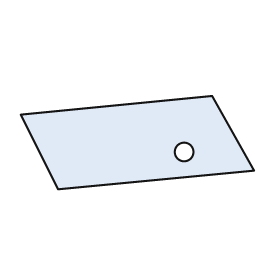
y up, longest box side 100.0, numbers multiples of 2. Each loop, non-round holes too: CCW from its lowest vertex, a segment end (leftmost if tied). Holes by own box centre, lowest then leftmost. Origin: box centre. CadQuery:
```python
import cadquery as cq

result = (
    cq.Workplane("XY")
    .moveTo(-34.0, -20.0)
    .lineTo(50.0, -12.0)
    .lineTo(32.0, 20.0)
    .lineTo(-50.0, 12.0)
    .close()
    .moveTo(20.0, -4.0)
    .circle(4.0)
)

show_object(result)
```